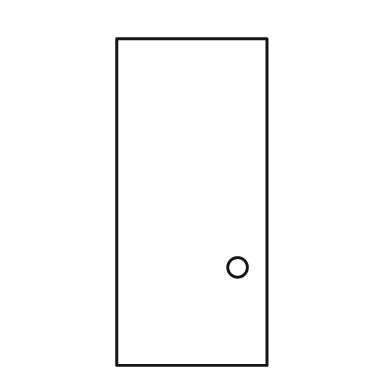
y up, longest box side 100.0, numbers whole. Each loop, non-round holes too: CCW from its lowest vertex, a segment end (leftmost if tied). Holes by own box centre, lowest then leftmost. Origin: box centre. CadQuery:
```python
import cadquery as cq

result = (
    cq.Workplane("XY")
    .moveTo(-23.0, -50.0)
    .lineTo(23.0, -50.0)
    .lineTo(23.0, 50.0)
    .lineTo(-23.0, 50.0)
    .close()
    .moveTo(14.0, -20.0)
    .circle(3.0)
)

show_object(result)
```